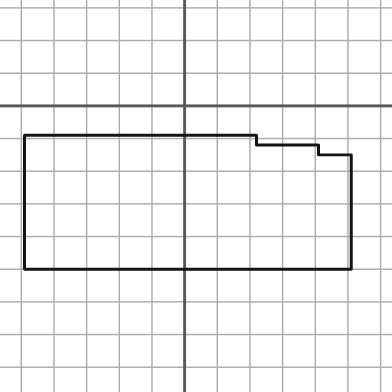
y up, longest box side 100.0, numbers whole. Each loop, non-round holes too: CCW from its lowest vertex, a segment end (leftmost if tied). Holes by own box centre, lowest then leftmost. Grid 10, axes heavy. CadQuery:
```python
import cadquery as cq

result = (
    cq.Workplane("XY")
    .moveTo(-49.0, -50.0)
    .lineTo(51.0, -50.0)
    .lineTo(51.0, -15.0)
    .lineTo(41.0, -15.0)
    .lineTo(41.0, -12.0)
    .lineTo(22.0, -12.0)
    .lineTo(22.0, -9.0)
    .lineTo(-49.0, -9.0)
    .close()
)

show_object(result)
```